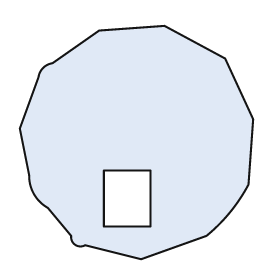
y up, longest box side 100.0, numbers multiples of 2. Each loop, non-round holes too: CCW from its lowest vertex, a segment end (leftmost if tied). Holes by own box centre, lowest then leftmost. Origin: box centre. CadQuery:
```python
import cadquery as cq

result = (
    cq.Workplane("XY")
    .moveTo(2.0, -50.0)
    .lineTo(30.0, -40.0)
    .threePointArc((40.0, -30.0), (48.0, -18.0))
    .lineTo(50.0, 10.0)
    .lineTo(38.0, 36.0)
    .lineTo(12.0, 50.0)
    .lineTo(-16.0, 48.0)
    .lineTo(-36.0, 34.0)
    .threePointArc((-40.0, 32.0), (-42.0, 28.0))
    .lineTo(-50.0, 6.0)
    .lineTo(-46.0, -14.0)
    .threePointArc((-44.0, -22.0), (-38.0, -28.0))
    .lineTo(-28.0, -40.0)
    .threePointArc((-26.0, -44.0), (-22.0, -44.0))
    .close()
    .moveTo(-14.0, -36.0)
    .lineTo(6.0, -36.0)
    .lineTo(6.0, -12.0)
    .lineTo(-14.0, -12.0)
    .close()
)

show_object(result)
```